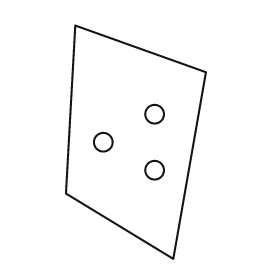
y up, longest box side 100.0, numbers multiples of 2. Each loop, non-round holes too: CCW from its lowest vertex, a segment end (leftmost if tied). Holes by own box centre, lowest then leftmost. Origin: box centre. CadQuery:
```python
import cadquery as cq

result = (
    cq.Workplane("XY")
    .moveTo(16.0, -50.0)
    .lineTo(30.0, 30.0)
    .lineTo(-26.0, 50.0)
    .lineTo(-30.0, -22.0)
    .close()
    .moveTo(8.0, -12.0)
    .circle(4.0)
    .moveTo(-14.0, 0.0)
    .circle(4.0)
    .moveTo(8.0, 12.0)
    .circle(4.0)
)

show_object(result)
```